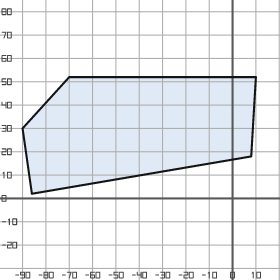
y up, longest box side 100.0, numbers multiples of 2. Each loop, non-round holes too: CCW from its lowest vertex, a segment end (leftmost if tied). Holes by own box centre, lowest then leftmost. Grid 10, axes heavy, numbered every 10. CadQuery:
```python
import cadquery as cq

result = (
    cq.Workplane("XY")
    .moveTo(-86.0, 2.0)
    .lineTo(8.0, 18.0)
    .lineTo(10.0, 52.0)
    .lineTo(-70.0, 52.0)
    .lineTo(-90.0, 30.0)
    .close()
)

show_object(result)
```